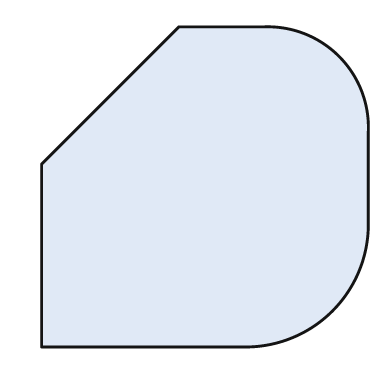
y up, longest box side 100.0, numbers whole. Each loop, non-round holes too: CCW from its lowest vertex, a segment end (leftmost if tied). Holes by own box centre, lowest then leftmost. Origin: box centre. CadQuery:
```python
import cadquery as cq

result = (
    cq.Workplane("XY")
    .moveTo(-50.0, -49.0)
    .lineTo(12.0, -49.0)
    .threePointArc((39.0, -38.0), (50.0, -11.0))
    .lineTo(50.0, 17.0)
    .threePointArc((41.0, 40.0), (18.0, 49.0))
    .lineTo(-8.0, 49.0)
    .lineTo(-50.0, 7.0)
    .close()
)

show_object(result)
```